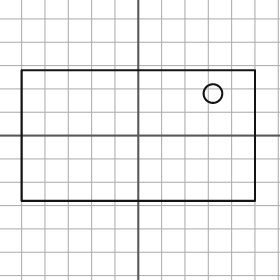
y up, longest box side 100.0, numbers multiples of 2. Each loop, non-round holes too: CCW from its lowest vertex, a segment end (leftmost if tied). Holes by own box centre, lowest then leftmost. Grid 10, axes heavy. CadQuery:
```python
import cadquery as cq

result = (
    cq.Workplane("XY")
    .moveTo(-50.0, -28.0)
    .lineTo(50.0, -28.0)
    .lineTo(50.0, 28.0)
    .lineTo(-50.0, 28.0)
    .close()
    .moveTo(32.0, 18.0)
    .circle(4.0)
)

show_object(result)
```